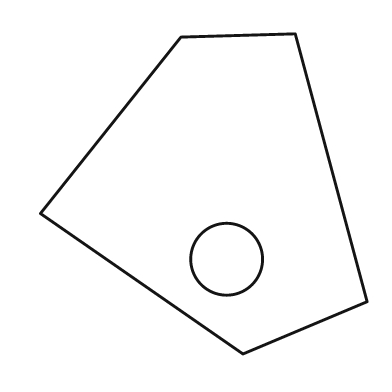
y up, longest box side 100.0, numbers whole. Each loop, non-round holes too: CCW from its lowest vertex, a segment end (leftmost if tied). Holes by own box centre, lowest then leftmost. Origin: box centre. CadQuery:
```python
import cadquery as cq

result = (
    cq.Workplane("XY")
    .moveTo(12.0, -49.0)
    .lineTo(50.0, -33.0)
    .lineTo(28.0, 49.0)
    .lineTo(-7.0, 48.0)
    .lineTo(-50.0, -6.0)
    .close()
    .moveTo(7.0, -20.0)
    .circle(11.0)
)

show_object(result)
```